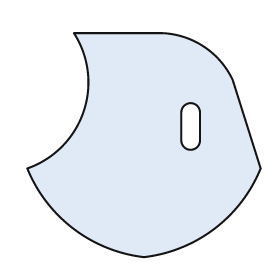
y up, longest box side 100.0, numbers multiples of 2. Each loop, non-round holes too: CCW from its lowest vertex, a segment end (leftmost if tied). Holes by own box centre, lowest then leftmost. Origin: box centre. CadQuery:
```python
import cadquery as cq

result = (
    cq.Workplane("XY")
    .moveTo(0.0, -48.0)
    .threePointArc((30.0, -36.0), (50.0, -10.0))
    .lineTo(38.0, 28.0)
    .threePointArc((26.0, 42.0), (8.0, 48.0))
    .lineTo(-30.0, 48.0)
    .threePointArc((-26.0, 14.0), (-50.0, -10.0))
    .threePointArc((-30.0, -36.0), (0.0, -48.0))
    .close()
    .moveTo(16.0, 2.0)
    .threePointArc((20.0, -2.0), (24.0, 2.0))
    .lineTo(24.0, 14.0)
    .threePointArc((20.0, 18.0), (16.0, 14.0))
    .close()
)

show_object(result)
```